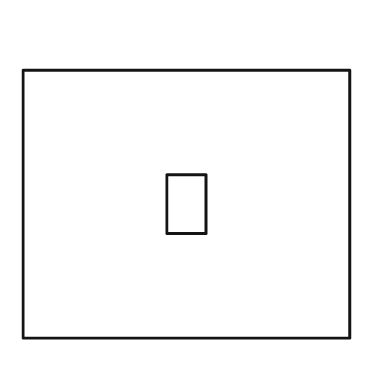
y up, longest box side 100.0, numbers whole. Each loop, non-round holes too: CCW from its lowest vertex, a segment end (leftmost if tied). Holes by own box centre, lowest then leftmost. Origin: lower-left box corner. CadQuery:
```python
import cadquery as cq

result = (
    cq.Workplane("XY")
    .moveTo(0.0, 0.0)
    .lineTo(100.0, 0.0)
    .lineTo(100.0, 82.0)
    .lineTo(0.0, 82.0)
    .close()
    .moveTo(44.0, 32.0)
    .lineTo(56.0, 32.0)
    .lineTo(56.0, 50.0)
    .lineTo(44.0, 50.0)
    .close()
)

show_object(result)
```